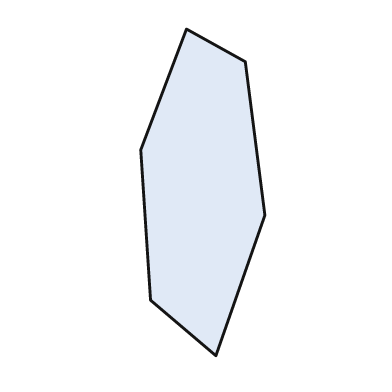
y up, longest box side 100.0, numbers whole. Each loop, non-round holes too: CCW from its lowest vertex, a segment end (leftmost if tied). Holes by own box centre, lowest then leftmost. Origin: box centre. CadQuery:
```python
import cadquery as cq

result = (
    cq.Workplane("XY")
    .moveTo(4.0, -50.0)
    .lineTo(19.0, -7.0)
    .lineTo(13.0, 40.0)
    .lineTo(-5.0, 50.0)
    .lineTo(-19.0, 13.0)
    .lineTo(-16.0, -33.0)
    .close()
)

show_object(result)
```